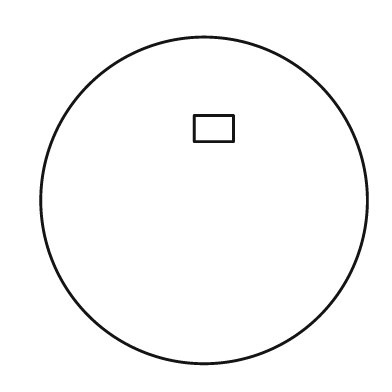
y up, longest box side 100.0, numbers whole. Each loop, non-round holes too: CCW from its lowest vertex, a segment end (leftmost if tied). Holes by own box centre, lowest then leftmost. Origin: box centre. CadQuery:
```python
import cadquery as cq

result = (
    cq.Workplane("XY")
    .moveTo(0.0, 0.0)
    .circle(50.0)
    .moveTo(-3.0, 18.0)
    .lineTo(9.0, 18.0)
    .lineTo(9.0, 26.0)
    .lineTo(-3.0, 26.0)
    .close()
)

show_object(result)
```